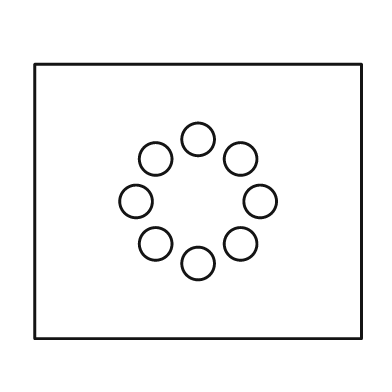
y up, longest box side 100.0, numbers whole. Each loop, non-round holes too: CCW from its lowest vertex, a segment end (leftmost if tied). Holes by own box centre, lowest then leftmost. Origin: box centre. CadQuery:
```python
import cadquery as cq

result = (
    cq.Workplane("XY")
    .moveTo(-50.0, -42.0)
    .lineTo(50.0, -42.0)
    .lineTo(50.0, 42.0)
    .lineTo(-50.0, 42.0)
    .close()
    .moveTo(0.0, -19.0)
    .circle(5.0)
    .moveTo(-13.0, -13.0)
    .circle(5.0)
    .moveTo(13.0, -13.0)
    .circle(5.0)
    .moveTo(-19.0, 0.0)
    .circle(5.0)
    .moveTo(19.0, 0.0)
    .circle(5.0)
    .moveTo(-13.0, 13.0)
    .circle(5.0)
    .moveTo(13.0, 13.0)
    .circle(5.0)
    .moveTo(0.0, 19.0)
    .circle(5.0)
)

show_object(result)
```